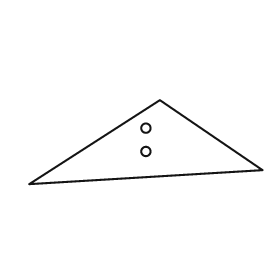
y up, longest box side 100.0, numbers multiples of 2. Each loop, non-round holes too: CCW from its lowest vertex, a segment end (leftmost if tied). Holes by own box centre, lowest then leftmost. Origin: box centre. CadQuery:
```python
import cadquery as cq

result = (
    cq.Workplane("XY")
    .moveTo(-50.0, -18.0)
    .lineTo(50.0, -12.0)
    .lineTo(6.0, 18.0)
    .close()
    .moveTo(0.0, -4.0)
    .circle(2.0)
    .moveTo(0.0, 6.0)
    .circle(2.0)
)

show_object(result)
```